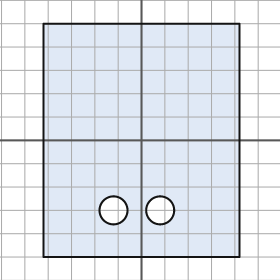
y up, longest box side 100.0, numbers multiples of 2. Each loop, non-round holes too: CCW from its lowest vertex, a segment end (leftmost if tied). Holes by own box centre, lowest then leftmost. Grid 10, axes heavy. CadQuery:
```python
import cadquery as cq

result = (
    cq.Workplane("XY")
    .moveTo(-42.0, -50.0)
    .lineTo(42.0, -50.0)
    .lineTo(42.0, 50.0)
    .lineTo(-42.0, 50.0)
    .close()
    .moveTo(-12.0, -30.0)
    .circle(6.0)
    .moveTo(8.0, -30.0)
    .circle(6.0)
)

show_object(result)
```